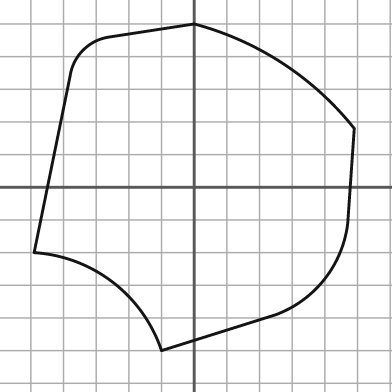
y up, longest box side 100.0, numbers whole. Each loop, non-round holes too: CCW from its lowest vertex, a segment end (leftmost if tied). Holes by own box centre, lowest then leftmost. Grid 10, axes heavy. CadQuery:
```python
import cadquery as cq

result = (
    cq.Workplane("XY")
    .moveTo(-10.0, -50.0)
    .lineTo(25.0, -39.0)
    .threePointArc((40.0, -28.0), (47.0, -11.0))
    .lineTo(49.0, 18.0)
    .threePointArc((27.0, 38.0), (0.0, 50.0))
    .lineTo(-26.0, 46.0)
    .threePointArc((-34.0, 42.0), (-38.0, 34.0))
    .lineTo(-49.0, -20.0)
    .threePointArc((-25.0, -29.0), (-10.0, -50.0))
    .close()
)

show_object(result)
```